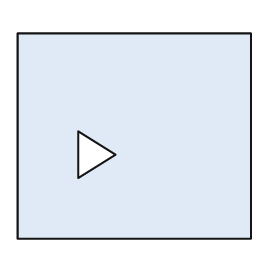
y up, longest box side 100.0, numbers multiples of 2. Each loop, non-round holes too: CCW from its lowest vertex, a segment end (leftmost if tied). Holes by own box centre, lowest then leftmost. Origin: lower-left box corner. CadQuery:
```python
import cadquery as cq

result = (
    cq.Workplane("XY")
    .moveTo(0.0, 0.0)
    .lineTo(100.0, 0.0)
    .lineTo(100.0, 88.0)
    .lineTo(0.0, 88.0)
    .close()
    .moveTo(26.0, 26.0)
    .lineTo(42.0, 36.0)
    .lineTo(26.0, 46.0)
    .close()
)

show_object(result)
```